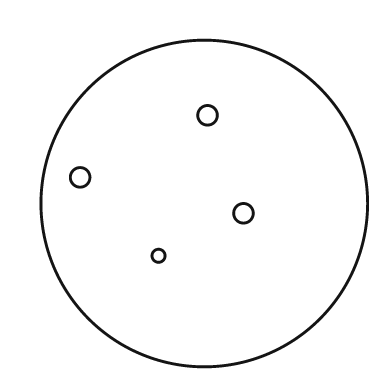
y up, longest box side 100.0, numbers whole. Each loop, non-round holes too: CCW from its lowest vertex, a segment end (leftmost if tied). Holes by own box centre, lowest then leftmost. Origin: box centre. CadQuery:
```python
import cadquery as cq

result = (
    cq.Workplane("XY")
    .moveTo(0.0, 0.0)
    .circle(50.0)
    .moveTo(-14.0, -16.0)
    .circle(2.0)
    .moveTo(12.0, -3.0)
    .circle(3.0)
    .moveTo(-38.0, 8.0)
    .circle(3.0)
    .moveTo(1.0, 27.0)
    .circle(3.0)
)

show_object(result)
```